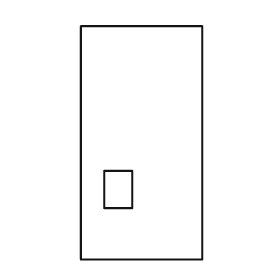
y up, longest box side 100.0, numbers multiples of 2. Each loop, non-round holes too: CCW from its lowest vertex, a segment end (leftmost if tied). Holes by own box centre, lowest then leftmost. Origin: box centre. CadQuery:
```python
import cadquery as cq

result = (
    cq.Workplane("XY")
    .moveTo(-26.0, -50.0)
    .lineTo(26.0, -50.0)
    .lineTo(26.0, 50.0)
    .lineTo(-26.0, 50.0)
    .close()
    .moveTo(-16.0, -28.0)
    .lineTo(-4.0, -28.0)
    .lineTo(-4.0, -12.0)
    .lineTo(-16.0, -12.0)
    .close()
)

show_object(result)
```